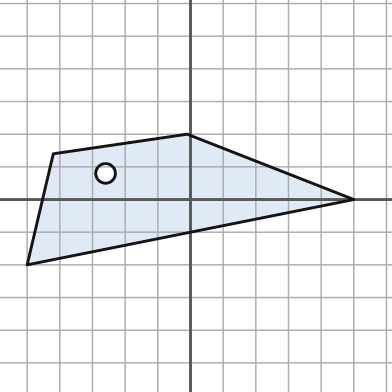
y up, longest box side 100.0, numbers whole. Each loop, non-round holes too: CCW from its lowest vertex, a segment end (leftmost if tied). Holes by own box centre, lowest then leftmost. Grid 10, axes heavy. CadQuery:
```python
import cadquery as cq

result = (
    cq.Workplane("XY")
    .moveTo(-50.0, -20.0)
    .lineTo(50.0, 0.0)
    .lineTo(-1.0, 20.0)
    .lineTo(-42.0, 14.0)
    .close()
    .moveTo(-26.0, 8.0)
    .circle(3.0)
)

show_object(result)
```